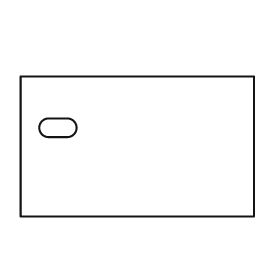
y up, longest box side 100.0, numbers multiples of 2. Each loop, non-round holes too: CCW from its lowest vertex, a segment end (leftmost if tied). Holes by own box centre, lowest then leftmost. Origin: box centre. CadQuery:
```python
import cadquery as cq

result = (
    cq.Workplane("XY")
    .moveTo(-50.0, -30.0)
    .lineTo(50.0, -30.0)
    .lineTo(50.0, 30.0)
    .lineTo(-50.0, 30.0)
    .close()
    .moveTo(-38.0, 4.0)
    .lineTo(-30.0, 4.0)
    .threePointArc((-26.0, 8.0), (-30.0, 12.0))
    .lineTo(-38.0, 12.0)
    .threePointArc((-42.0, 8.0), (-38.0, 4.0))
    .close()
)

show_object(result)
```